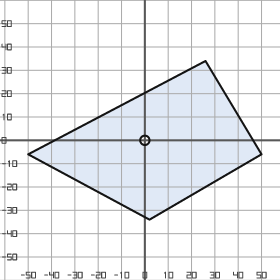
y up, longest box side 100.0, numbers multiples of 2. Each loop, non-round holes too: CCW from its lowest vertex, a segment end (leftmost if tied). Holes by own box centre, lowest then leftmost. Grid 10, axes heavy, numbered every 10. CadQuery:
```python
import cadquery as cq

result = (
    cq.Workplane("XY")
    .moveTo(2.0, -34.0)
    .lineTo(50.0, -6.0)
    .lineTo(26.0, 34.0)
    .lineTo(-50.0, -6.0)
    .close()
    .moveTo(0.0, 0.0)
    .circle(2.0)
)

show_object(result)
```